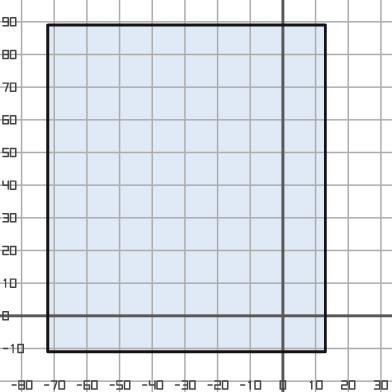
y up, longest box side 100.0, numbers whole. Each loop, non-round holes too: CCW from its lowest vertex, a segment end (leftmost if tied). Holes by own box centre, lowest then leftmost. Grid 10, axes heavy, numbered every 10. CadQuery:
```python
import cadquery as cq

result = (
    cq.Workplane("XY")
    .moveTo(-72.0, -11.0)
    .lineTo(13.0, -11.0)
    .lineTo(13.0, 89.0)
    .lineTo(-72.0, 89.0)
    .close()
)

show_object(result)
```